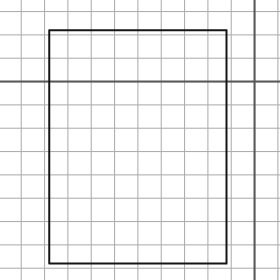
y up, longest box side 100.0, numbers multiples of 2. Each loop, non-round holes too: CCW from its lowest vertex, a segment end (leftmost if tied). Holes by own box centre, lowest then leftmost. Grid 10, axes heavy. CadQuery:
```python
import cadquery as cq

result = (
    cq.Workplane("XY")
    .moveTo(-88.0, -78.0)
    .lineTo(-12.0, -78.0)
    .lineTo(-12.0, 22.0)
    .lineTo(-88.0, 22.0)
    .close()
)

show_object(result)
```